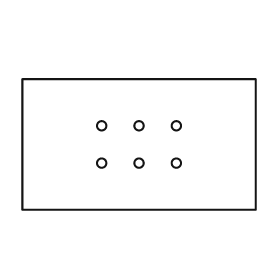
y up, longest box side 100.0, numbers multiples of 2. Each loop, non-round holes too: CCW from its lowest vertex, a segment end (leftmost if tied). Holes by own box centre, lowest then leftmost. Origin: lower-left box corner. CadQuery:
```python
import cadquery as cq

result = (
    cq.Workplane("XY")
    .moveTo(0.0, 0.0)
    .lineTo(100.0, 0.0)
    .lineTo(100.0, 56.0)
    .lineTo(0.0, 56.0)
    .close()
    .moveTo(34.0, 20.0)
    .circle(2.0)
    .moveTo(50.0, 20.0)
    .circle(2.0)
    .moveTo(66.0, 20.0)
    .circle(2.0)
    .moveTo(34.0, 36.0)
    .circle(2.0)
    .moveTo(50.0, 36.0)
    .circle(2.0)
    .moveTo(66.0, 36.0)
    .circle(2.0)
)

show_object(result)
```